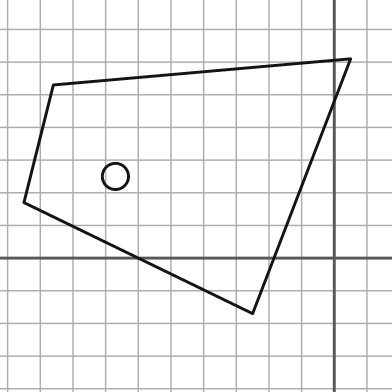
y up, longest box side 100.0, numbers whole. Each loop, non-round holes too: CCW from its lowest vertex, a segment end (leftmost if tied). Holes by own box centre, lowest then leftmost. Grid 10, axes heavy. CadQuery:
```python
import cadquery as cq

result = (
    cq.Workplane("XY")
    .moveTo(-25.0, -17.0)
    .lineTo(5.0, 61.0)
    .lineTo(-86.0, 53.0)
    .lineTo(-95.0, 17.0)
    .close()
    .moveTo(-67.0, 25.0)
    .circle(4.0)
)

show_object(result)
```